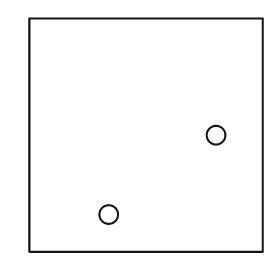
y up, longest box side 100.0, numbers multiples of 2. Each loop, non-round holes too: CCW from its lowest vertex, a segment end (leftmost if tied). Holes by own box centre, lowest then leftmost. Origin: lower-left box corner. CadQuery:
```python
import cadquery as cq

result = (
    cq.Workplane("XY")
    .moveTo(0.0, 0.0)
    .lineTo(100.0, 0.0)
    .lineTo(100.0, 100.0)
    .lineTo(0.0, 100.0)
    .close()
    .moveTo(34.0, 16.0)
    .circle(4.0)
    .moveTo(80.0, 50.0)
    .circle(4.0)
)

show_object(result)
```